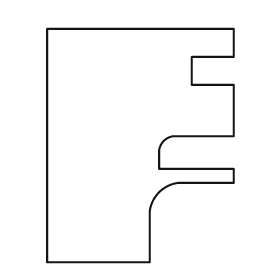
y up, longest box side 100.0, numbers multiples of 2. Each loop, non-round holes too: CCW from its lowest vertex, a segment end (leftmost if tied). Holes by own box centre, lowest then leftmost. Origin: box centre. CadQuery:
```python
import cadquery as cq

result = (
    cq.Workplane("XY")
    .moveTo(-40.0, -50.0)
    .lineTo(4.0, -50.0)
    .lineTo(4.0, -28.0)
    .threePointArc((8.0, -20.0), (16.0, -16.0))
    .lineTo(40.0, -16.0)
    .lineTo(40.0, -10.0)
    .lineTo(8.0, -10.0)
    .lineTo(8.0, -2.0)
    .threePointArc((10.0, 2.0), (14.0, 4.0))
    .lineTo(40.0, 4.0)
    .lineTo(40.0, 26.0)
    .lineTo(22.0, 26.0)
    .lineTo(22.0, 38.0)
    .lineTo(40.0, 38.0)
    .lineTo(40.0, 50.0)
    .lineTo(-40.0, 50.0)
    .close()
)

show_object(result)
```